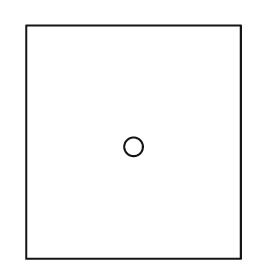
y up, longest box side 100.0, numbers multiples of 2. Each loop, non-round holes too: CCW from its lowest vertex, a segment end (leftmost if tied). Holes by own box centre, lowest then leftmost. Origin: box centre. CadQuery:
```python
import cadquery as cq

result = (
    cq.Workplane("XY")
    .moveTo(-46.0, -50.0)
    .lineTo(46.0, -50.0)
    .lineTo(46.0, 50.0)
    .lineTo(-46.0, 50.0)
    .close()
    .moveTo(0.0, -2.0)
    .circle(4.0)
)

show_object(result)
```